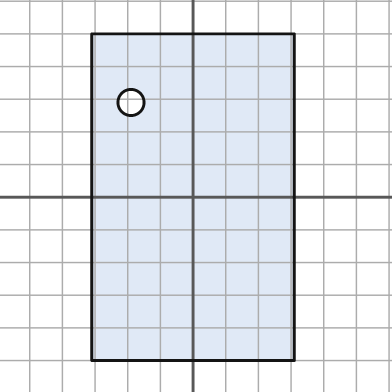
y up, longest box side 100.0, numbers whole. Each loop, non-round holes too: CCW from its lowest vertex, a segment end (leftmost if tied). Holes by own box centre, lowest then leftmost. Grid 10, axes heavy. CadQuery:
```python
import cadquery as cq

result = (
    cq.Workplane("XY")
    .moveTo(-31.0, -50.0)
    .lineTo(31.0, -50.0)
    .lineTo(31.0, 50.0)
    .lineTo(-31.0, 50.0)
    .close()
    .moveTo(-19.0, 29.0)
    .circle(4.0)
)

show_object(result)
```